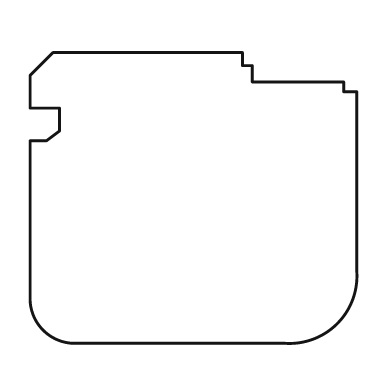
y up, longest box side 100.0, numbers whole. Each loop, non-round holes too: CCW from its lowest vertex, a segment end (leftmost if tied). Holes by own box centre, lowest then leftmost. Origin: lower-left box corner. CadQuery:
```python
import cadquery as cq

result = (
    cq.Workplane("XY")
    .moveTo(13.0, 0.0)
    .lineTo(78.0, 0.0)
    .threePointArc((94.0, 6.0), (100.0, 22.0))
    .lineTo(100.0, 77.0)
    .lineTo(96.0, 77.0)
    .lineTo(96.0, 80.0)
    .lineTo(68.0, 80.0)
    .lineTo(68.0, 85.0)
    .lineTo(65.0, 85.0)
    .lineTo(65.0, 89.0)
    .lineTo(7.0, 89.0)
    .lineTo(0.0, 82.0)
    .lineTo(0.0, 72.0)
    .lineTo(9.0, 72.0)
    .lineTo(9.0, 65.0)
    .lineTo(5.0, 62.0)
    .lineTo(0.0, 62.0)
    .lineTo(0.0, 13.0)
    .threePointArc((4.0, 4.0), (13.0, 0.0))
    .close()
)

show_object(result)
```